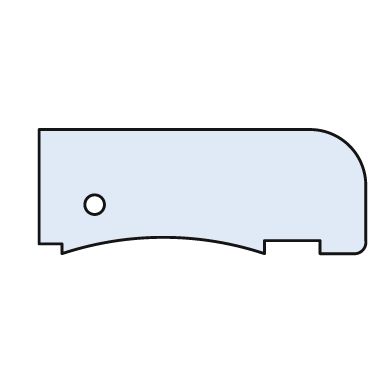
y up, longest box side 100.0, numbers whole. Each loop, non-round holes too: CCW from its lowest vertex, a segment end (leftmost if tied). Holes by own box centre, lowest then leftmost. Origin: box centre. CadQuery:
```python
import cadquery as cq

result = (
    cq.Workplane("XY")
    .moveTo(-43.0, -19.0)
    .threePointArc((-12.0, -14.0), (19.0, -19.0))
    .lineTo(19.0, -15.0)
    .lineTo(36.0, -15.0)
    .lineTo(36.0, -19.0)
    .lineTo(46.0, -19.0)
    .threePointArc((49.0, -18.0), (50.0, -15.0))
    .lineTo(50.0, 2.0)
    .threePointArc((45.0, 14.0), (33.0, 19.0))
    .lineTo(-50.0, 19.0)
    .lineTo(-50.0, -16.0)
    .lineTo(-43.0, -16.0)
    .close()
    .moveTo(-33.0, -4.0)
    .circle(3.0)
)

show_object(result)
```